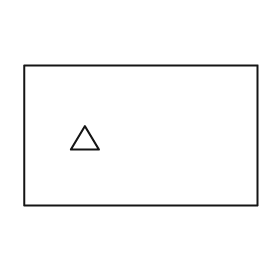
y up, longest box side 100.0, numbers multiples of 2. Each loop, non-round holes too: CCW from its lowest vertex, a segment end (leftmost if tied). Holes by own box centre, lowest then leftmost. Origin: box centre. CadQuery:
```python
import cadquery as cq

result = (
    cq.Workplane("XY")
    .moveTo(-50.0, -30.0)
    .lineTo(50.0, -30.0)
    .lineTo(50.0, 30.0)
    .lineTo(-50.0, 30.0)
    .close()
    .moveTo(-30.0, -6.0)
    .lineTo(-18.0, -6.0)
    .lineTo(-24.0, 4.0)
    .close()
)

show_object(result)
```